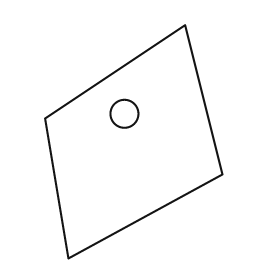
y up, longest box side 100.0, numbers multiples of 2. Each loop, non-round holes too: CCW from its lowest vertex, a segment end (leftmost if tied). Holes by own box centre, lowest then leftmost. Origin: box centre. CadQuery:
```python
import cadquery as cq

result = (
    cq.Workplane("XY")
    .moveTo(-28.0, -50.0)
    .lineTo(38.0, -14.0)
    .lineTo(22.0, 50.0)
    .lineTo(-38.0, 10.0)
    .close()
    .moveTo(-4.0, 12.0)
    .circle(6.0)
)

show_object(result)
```